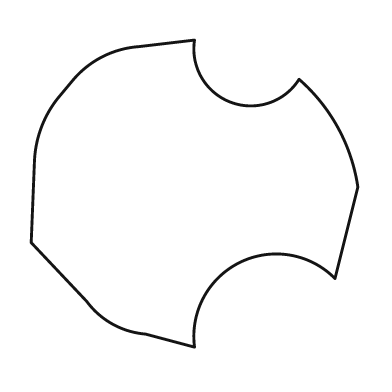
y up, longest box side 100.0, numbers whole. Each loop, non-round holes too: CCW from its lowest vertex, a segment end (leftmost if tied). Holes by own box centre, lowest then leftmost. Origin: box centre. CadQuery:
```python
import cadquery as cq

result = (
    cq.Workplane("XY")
    .moveTo(0.0, -47.0)
    .threePointArc((14.0, -21.0), (43.0, -26.0))
    .lineTo(50.0, 2.0)
    .threePointArc((44.0, 20.0), (32.0, 35.0))
    .threePointArc((11.0, 28.0), (0.0, 47.0))
    .lineTo(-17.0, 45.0)
    .threePointArc((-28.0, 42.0), (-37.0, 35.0))
    .lineTo(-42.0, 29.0)
    .threePointArc((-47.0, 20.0), (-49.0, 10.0))
    .lineTo(-50.0, -15.0)
    .lineTo(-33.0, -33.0)
    .threePointArc((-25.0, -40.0), (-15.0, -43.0))
    .close()
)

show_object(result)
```